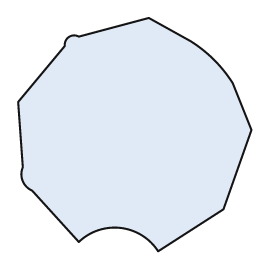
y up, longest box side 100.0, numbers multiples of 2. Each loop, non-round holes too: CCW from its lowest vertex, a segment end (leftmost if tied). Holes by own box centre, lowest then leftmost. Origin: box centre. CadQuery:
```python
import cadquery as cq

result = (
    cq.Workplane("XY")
    .moveTo(10.0, -50.0)
    .lineTo(38.0, -32.0)
    .lineTo(50.0, 2.0)
    .lineTo(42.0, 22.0)
    .threePointArc((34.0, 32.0), (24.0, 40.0))
    .lineTo(6.0, 50.0)
    .lineTo(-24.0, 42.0)
    .threePointArc((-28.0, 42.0), (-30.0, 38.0))
    .lineTo(-50.0, 14.0)
    .lineTo(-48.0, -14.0)
    .threePointArc((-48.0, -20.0), (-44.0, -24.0))
    .lineTo(-24.0, -46.0)
    .threePointArc((-6.0, -40.0), (10.0, -50.0))
    .close()
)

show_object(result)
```